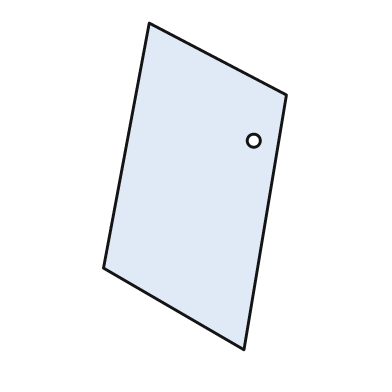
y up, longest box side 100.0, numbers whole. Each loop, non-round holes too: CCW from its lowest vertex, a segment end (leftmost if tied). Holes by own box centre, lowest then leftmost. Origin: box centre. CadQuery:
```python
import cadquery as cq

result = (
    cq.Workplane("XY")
    .moveTo(15.0, -50.0)
    .lineTo(28.0, 28.0)
    .lineTo(-14.0, 50.0)
    .lineTo(-28.0, -25.0)
    .close()
    .moveTo(18.0, 14.0)
    .circle(2.0)
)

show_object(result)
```